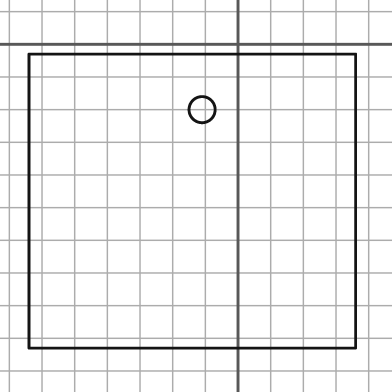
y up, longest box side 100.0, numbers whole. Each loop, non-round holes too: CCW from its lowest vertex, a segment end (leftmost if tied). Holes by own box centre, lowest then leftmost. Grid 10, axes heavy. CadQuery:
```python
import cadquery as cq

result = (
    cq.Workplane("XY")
    .moveTo(-64.0, -93.0)
    .lineTo(36.0, -93.0)
    .lineTo(36.0, -3.0)
    .lineTo(-64.0, -3.0)
    .close()
    .moveTo(-11.0, -20.0)
    .circle(4.0)
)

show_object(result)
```